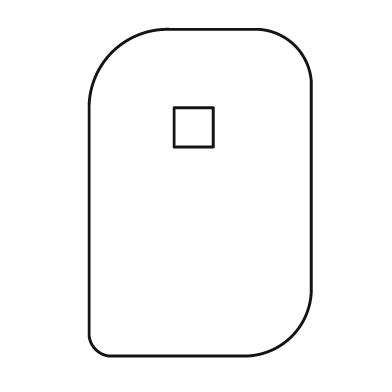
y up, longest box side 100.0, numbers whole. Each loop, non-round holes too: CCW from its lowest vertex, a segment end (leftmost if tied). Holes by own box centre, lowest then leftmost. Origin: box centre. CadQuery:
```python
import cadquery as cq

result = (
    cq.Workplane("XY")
    .moveTo(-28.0, -50.0)
    .lineTo(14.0, -50.0)
    .threePointArc((28.0, -44.0), (34.0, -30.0))
    .lineTo(34.0, 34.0)
    .threePointArc((29.0, 45.0), (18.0, 50.0))
    .lineTo(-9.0, 50.0)
    .threePointArc((-27.0, 43.0), (-34.0, 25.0))
    .lineTo(-34.0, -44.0)
    .threePointArc((-32.0, -48.0), (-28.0, -50.0))
    .close()
    .moveTo(-8.0, 14.0)
    .lineTo(4.0, 14.0)
    .lineTo(4.0, 26.0)
    .lineTo(-8.0, 26.0)
    .close()
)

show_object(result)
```